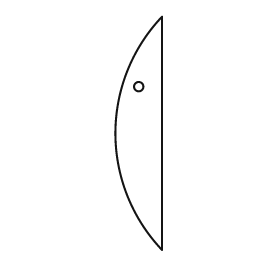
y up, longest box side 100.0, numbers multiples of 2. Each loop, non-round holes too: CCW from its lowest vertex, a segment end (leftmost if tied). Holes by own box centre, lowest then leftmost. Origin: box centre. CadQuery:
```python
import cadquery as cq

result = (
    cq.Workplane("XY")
    .moveTo(10.0, -50.0)
    .lineTo(10.0, 50.0)
    .threePointArc((-10.0, 0.0), (10.0, -50.0))
    .close()
    .moveTo(0.0, 20.0)
    .circle(2.0)
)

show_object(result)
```